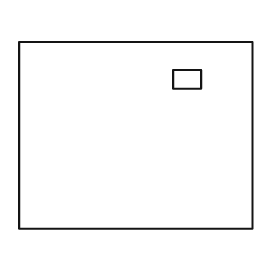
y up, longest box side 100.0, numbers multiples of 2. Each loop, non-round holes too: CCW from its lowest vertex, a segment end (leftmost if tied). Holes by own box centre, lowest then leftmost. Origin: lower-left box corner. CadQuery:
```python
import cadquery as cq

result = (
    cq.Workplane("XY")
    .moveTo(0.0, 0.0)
    .lineTo(100.0, 0.0)
    .lineTo(100.0, 80.0)
    .lineTo(0.0, 80.0)
    .close()
    .moveTo(66.0, 60.0)
    .lineTo(78.0, 60.0)
    .lineTo(78.0, 68.0)
    .lineTo(66.0, 68.0)
    .close()
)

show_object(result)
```